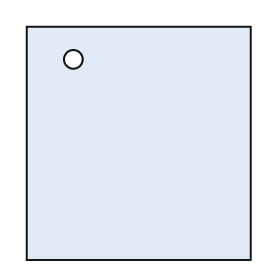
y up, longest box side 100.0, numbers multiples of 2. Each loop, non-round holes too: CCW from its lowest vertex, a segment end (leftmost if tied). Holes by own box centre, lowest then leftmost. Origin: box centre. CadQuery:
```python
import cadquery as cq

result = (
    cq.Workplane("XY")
    .moveTo(-48.0, -50.0)
    .lineTo(48.0, -50.0)
    .lineTo(48.0, 50.0)
    .lineTo(-48.0, 50.0)
    .close()
    .moveTo(-28.0, 36.0)
    .circle(4.0)
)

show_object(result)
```